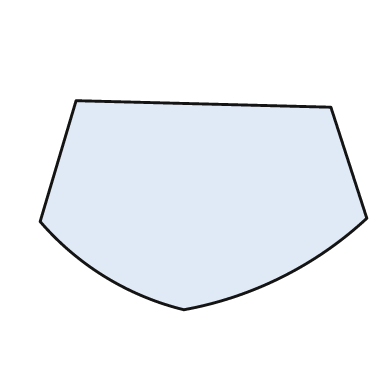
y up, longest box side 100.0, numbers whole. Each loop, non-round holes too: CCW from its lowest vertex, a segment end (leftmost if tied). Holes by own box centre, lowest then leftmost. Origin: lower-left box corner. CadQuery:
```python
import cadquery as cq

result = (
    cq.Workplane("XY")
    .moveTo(44.0, 0.0)
    .threePointArc((74.0, 10.0), (100.0, 28.0))
    .lineTo(89.0, 62.0)
    .lineTo(11.0, 64.0)
    .lineTo(0.0, 27.0)
    .threePointArc((20.0, 10.0), (44.0, 0.0))
    .close()
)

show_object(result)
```